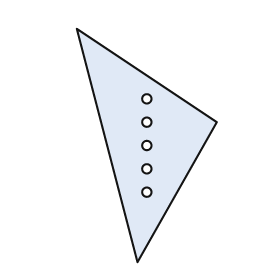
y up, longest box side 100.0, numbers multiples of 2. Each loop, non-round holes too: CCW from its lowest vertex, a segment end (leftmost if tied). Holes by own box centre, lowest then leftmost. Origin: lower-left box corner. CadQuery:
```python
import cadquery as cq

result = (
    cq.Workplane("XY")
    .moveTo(26.0, 0.0)
    .lineTo(60.0, 60.0)
    .lineTo(0.0, 100.0)
    .close()
    .moveTo(30.0, 30.0)
    .circle(2.0)
    .moveTo(30.0, 40.0)
    .circle(2.0)
    .moveTo(30.0, 50.0)
    .circle(2.0)
    .moveTo(30.0, 60.0)
    .circle(2.0)
    .moveTo(30.0, 70.0)
    .circle(2.0)
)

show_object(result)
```